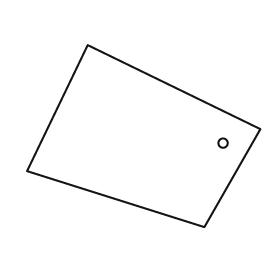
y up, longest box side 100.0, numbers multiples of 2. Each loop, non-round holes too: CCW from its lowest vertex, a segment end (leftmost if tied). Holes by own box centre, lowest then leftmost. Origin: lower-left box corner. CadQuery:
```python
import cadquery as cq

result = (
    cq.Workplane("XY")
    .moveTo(76.0, 0.0)
    .lineTo(100.0, 42.0)
    .lineTo(26.0, 78.0)
    .lineTo(0.0, 24.0)
    .close()
    .moveTo(84.0, 36.0)
    .circle(2.0)
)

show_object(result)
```